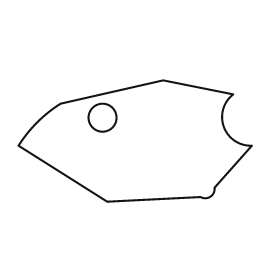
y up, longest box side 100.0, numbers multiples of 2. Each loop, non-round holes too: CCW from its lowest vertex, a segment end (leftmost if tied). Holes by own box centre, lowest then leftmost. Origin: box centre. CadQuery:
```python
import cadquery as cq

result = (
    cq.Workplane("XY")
    .moveTo(-12.0, -26.0)
    .lineTo(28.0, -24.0)
    .threePointArc((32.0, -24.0), (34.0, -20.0))
    .lineTo(50.0, -2.0)
    .threePointArc((38.0, 6.0), (42.0, 20.0))
    .lineTo(12.0, 26.0)
    .lineTo(-32.0, 16.0)
    .threePointArc((-42.0, 8.0), (-50.0, -2.0))
    .close()
    .moveTo(-14.0, 10.0)
    .circle(6.0)
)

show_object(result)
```